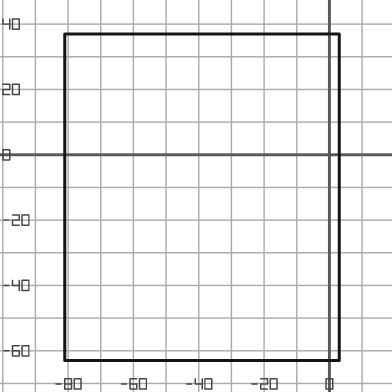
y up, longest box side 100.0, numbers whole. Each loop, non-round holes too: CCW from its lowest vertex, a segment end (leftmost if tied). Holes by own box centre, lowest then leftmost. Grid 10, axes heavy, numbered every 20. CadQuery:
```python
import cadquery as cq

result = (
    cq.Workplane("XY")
    .moveTo(-81.0, -63.0)
    .lineTo(3.0, -63.0)
    .lineTo(3.0, 37.0)
    .lineTo(-81.0, 37.0)
    .close()
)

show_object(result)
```